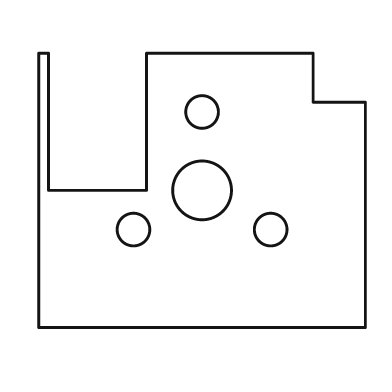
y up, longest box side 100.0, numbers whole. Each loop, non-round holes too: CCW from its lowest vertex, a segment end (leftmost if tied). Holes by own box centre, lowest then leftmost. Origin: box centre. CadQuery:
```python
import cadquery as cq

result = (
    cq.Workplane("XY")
    .moveTo(-50.0, -42.0)
    .lineTo(50.0, -42.0)
    .lineTo(50.0, 27.0)
    .lineTo(34.0, 27.0)
    .lineTo(34.0, 42.0)
    .lineTo(-17.0, 42.0)
    .lineTo(-17.0, 0.0)
    .lineTo(-47.0, 0.0)
    .lineTo(-47.0, 42.0)
    .lineTo(-50.0, 42.0)
    .close()
    .moveTo(-21.0, -12.0)
    .circle(5.0)
    .moveTo(21.0, -12.0)
    .circle(5.0)
    .moveTo(0.0, 0.0)
    .circle(9.0)
    .moveTo(0.0, 24.0)
    .circle(5.0)
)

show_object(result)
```